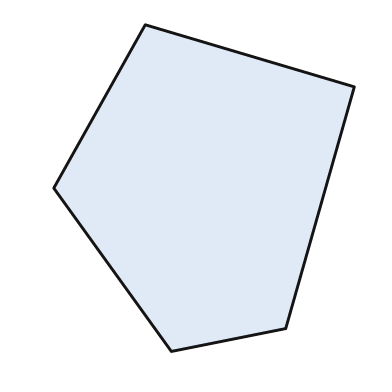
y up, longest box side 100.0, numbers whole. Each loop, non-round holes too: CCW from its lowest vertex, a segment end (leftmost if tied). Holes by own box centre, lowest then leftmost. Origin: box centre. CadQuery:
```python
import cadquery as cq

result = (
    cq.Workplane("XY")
    .moveTo(-10.0, -50.0)
    .lineTo(25.0, -43.0)
    .lineTo(46.0, 31.0)
    .lineTo(-18.0, 50.0)
    .lineTo(-46.0, 0.0)
    .close()
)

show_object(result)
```